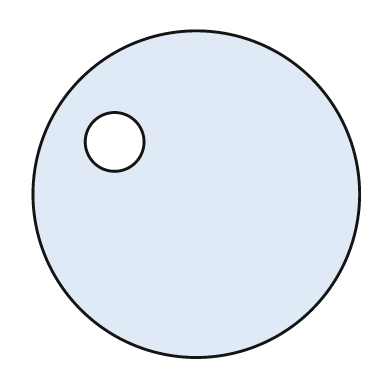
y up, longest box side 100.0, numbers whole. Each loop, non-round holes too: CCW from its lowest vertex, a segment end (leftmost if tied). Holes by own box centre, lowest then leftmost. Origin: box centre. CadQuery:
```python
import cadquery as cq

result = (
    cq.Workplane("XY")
    .moveTo(0.0, 0.0)
    .circle(50.0)
    .moveTo(-25.0, 16.0)
    .circle(9.0)
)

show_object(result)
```